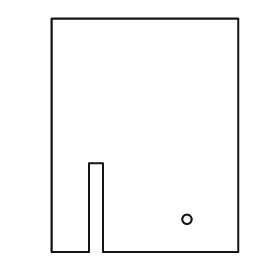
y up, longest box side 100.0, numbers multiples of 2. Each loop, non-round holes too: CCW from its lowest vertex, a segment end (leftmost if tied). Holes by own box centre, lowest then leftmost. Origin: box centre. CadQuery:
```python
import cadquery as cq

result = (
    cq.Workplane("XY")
    .moveTo(-40.0, -50.0)
    .lineTo(-24.0, -50.0)
    .lineTo(-24.0, -12.0)
    .lineTo(-18.0, -12.0)
    .lineTo(-18.0, -50.0)
    .lineTo(40.0, -50.0)
    .lineTo(40.0, 50.0)
    .lineTo(-40.0, 50.0)
    .close()
    .moveTo(18.0, -36.0)
    .circle(2.0)
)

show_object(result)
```